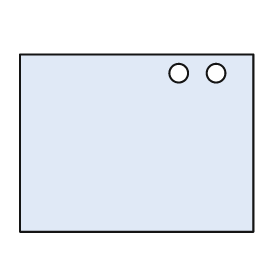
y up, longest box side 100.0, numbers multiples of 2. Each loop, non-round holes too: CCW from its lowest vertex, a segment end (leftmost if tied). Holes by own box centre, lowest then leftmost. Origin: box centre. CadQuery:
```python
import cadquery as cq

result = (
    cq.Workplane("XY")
    .moveTo(-50.0, -38.0)
    .lineTo(50.0, -38.0)
    .lineTo(50.0, 38.0)
    .lineTo(-50.0, 38.0)
    .close()
    .moveTo(18.0, 30.0)
    .circle(4.0)
    .moveTo(34.0, 30.0)
    .circle(4.0)
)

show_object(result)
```